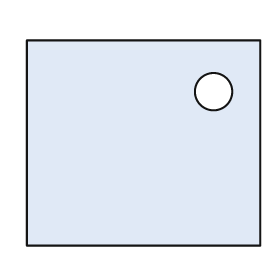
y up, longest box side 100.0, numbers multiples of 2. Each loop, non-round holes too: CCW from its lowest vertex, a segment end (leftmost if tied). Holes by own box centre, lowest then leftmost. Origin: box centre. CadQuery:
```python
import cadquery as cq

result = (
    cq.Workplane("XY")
    .moveTo(-50.0, -44.0)
    .lineTo(50.0, -44.0)
    .lineTo(50.0, 44.0)
    .lineTo(-50.0, 44.0)
    .close()
    .moveTo(30.0, 22.0)
    .circle(8.0)
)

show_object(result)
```